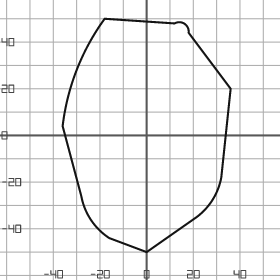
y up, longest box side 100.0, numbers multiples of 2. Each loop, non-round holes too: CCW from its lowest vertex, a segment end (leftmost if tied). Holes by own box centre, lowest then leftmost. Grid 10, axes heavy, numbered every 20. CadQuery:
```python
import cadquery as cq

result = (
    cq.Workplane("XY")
    .moveTo(0.0, -50.0)
    .lineTo(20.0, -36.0)
    .threePointArc((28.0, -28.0), (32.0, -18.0))
    .lineTo(36.0, 20.0)
    .lineTo(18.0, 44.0)
    .threePointArc((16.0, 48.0), (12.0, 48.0))
    .lineTo(-18.0, 50.0)
    .threePointArc((-30.0, 28.0), (-36.0, 4.0))
    .lineTo(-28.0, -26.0)
    .threePointArc((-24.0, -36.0), (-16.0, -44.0))
    .close()
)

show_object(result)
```